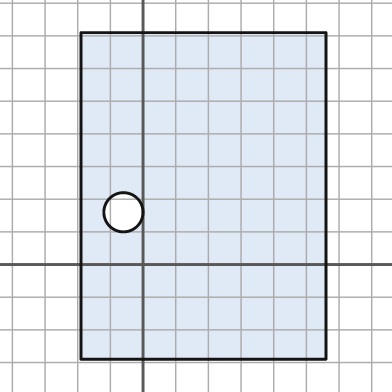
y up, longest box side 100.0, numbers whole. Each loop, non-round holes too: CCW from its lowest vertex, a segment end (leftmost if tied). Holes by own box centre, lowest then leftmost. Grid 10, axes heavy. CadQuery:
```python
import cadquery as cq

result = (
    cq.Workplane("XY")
    .moveTo(-19.0, -29.0)
    .lineTo(56.0, -29.0)
    .lineTo(56.0, 71.0)
    .lineTo(-19.0, 71.0)
    .close()
    .moveTo(-6.0, 16.0)
    .circle(6.0)
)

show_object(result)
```